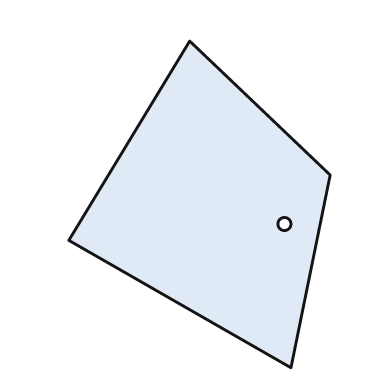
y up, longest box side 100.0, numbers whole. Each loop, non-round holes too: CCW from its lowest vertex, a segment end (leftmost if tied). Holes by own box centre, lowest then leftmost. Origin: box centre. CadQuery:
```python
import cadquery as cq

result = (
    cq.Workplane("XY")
    .moveTo(28.0, -50.0)
    .lineTo(40.0, 9.0)
    .lineTo(-3.0, 50.0)
    .lineTo(-40.0, -11.0)
    .close()
    .moveTo(26.0, -6.0)
    .circle(2.0)
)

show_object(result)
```